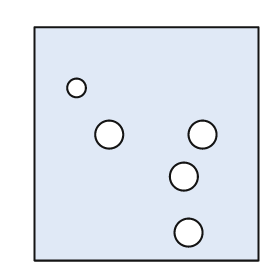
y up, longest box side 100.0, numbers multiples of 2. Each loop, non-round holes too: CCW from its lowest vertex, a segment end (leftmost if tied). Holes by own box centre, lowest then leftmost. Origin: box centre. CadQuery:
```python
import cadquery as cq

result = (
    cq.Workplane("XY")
    .moveTo(-48.0, -50.0)
    .lineTo(48.0, -50.0)
    .lineTo(48.0, 50.0)
    .lineTo(-48.0, 50.0)
    .close()
    .moveTo(18.0, -38.0)
    .circle(6.0)
    .moveTo(16.0, -14.0)
    .circle(6.0)
    .moveTo(-16.0, 4.0)
    .circle(6.0)
    .moveTo(24.0, 4.0)
    .circle(6.0)
    .moveTo(-30.0, 24.0)
    .circle(4.0)
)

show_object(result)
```